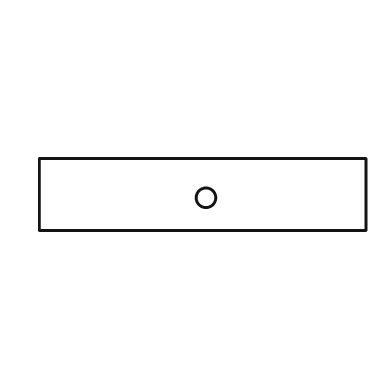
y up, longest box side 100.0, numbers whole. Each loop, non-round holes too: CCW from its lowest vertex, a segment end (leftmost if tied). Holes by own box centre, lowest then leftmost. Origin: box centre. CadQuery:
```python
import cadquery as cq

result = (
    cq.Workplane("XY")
    .moveTo(-50.0, -11.0)
    .lineTo(50.0, -11.0)
    .lineTo(50.0, 11.0)
    .lineTo(-50.0, 11.0)
    .close()
    .moveTo(1.0, -1.0)
    .circle(3.0)
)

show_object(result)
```